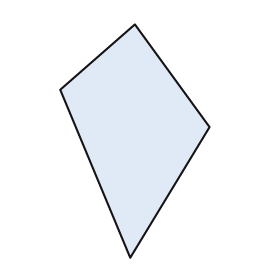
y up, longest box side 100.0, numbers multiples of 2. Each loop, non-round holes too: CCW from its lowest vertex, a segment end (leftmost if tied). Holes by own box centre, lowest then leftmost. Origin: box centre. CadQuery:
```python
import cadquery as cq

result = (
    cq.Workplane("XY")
    .moveTo(-2.0, -50.0)
    .lineTo(32.0, 6.0)
    .lineTo(0.0, 50.0)
    .lineTo(-32.0, 22.0)
    .close()
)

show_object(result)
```